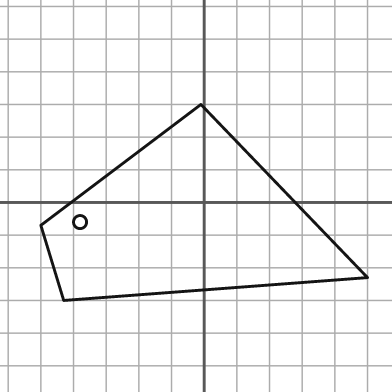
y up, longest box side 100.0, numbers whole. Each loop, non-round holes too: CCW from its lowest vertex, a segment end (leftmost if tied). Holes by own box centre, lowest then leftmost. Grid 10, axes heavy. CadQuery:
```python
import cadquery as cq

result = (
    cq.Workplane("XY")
    .moveTo(-43.0, -30.0)
    .lineTo(50.0, -23.0)
    .lineTo(-1.0, 30.0)
    .lineTo(-50.0, -7.0)
    .close()
    .moveTo(-38.0, -6.0)
    .circle(2.0)
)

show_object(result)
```